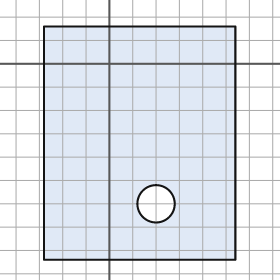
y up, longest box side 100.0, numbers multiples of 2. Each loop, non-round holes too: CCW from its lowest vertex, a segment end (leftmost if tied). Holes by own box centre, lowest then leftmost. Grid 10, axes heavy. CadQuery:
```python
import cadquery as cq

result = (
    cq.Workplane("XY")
    .moveTo(-28.0, -84.0)
    .lineTo(54.0, -84.0)
    .lineTo(54.0, 16.0)
    .lineTo(-28.0, 16.0)
    .close()
    .moveTo(20.0, -60.0)
    .circle(8.0)
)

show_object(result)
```